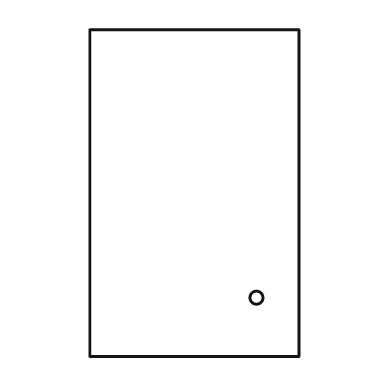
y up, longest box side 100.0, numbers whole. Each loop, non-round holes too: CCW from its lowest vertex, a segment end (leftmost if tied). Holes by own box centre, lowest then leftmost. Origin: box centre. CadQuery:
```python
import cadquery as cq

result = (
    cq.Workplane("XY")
    .moveTo(-32.0, -50.0)
    .lineTo(32.0, -50.0)
    .lineTo(32.0, 50.0)
    .lineTo(-32.0, 50.0)
    .close()
    .moveTo(19.0, -32.0)
    .circle(2.0)
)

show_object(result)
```